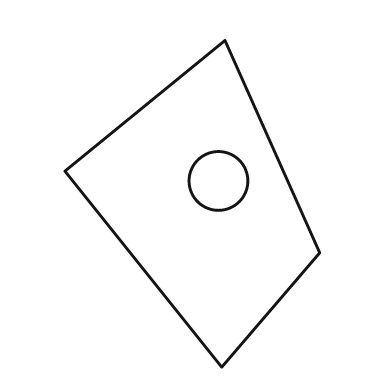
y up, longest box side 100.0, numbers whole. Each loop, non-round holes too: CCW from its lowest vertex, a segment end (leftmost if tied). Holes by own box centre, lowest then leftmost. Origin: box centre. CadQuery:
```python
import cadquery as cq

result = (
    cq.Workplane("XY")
    .moveTo(9.0, -50.0)
    .lineTo(39.0, -15.0)
    .lineTo(10.0, 50.0)
    .lineTo(-39.0, 10.0)
    .close()
    .moveTo(8.0, 7.0)
    .circle(9.0)
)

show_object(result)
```